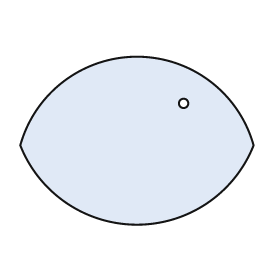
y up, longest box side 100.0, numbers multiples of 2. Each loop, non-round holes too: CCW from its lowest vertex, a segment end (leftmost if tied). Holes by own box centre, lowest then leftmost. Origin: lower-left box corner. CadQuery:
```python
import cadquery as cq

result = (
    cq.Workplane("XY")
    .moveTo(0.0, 34.0)
    .threePointArc((50.0, 0.0), (100.0, 34.0))
    .threePointArc((50.0, 72.0), (0.0, 34.0))
    .close()
    .moveTo(70.0, 52.0)
    .circle(2.0)
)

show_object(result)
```